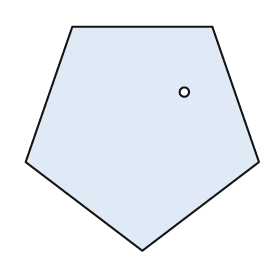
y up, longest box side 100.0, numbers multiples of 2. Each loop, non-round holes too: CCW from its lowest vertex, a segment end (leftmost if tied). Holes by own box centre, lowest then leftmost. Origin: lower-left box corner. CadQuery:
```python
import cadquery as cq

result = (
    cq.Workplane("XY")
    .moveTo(50.0, 0.0)
    .lineTo(100.0, 38.0)
    .lineTo(80.0, 96.0)
    .lineTo(20.0, 96.0)
    .lineTo(0.0, 38.0)
    .close()
    .moveTo(68.0, 68.0)
    .circle(2.0)
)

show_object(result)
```